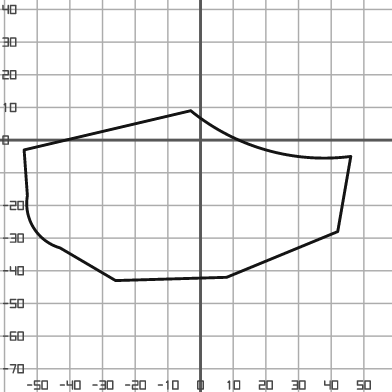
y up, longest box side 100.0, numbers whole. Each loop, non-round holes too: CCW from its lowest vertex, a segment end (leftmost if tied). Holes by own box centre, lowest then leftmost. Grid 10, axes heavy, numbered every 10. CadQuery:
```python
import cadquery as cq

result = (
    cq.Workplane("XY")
    .moveTo(-26.0, -43.0)
    .lineTo(8.0, -42.0)
    .lineTo(42.0, -28.0)
    .lineTo(46.0, -5.0)
    .threePointArc((20.0, -3.0), (-3.0, 9.0))
    .lineTo(-54.0, -3.0)
    .lineTo(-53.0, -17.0)
    .threePointArc((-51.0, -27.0), (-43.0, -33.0))
    .close()
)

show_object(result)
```